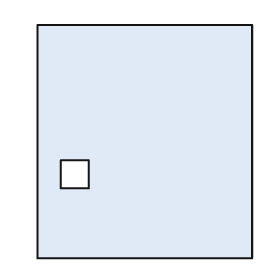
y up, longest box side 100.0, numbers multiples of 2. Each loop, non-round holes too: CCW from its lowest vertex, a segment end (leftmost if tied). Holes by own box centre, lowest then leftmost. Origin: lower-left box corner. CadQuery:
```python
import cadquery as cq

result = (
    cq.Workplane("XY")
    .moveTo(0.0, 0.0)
    .lineTo(92.0, 0.0)
    .lineTo(92.0, 100.0)
    .lineTo(0.0, 100.0)
    .close()
    .moveTo(10.0, 30.0)
    .lineTo(22.0, 30.0)
    .lineTo(22.0, 42.0)
    .lineTo(10.0, 42.0)
    .close()
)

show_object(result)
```